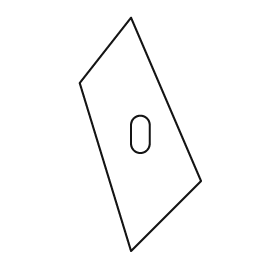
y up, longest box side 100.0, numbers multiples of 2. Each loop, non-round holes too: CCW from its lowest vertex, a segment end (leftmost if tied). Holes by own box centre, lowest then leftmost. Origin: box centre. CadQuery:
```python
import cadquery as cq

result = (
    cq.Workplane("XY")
    .moveTo(-4.0, -50.0)
    .lineTo(26.0, -20.0)
    .lineTo(-4.0, 50.0)
    .lineTo(-26.0, 22.0)
    .close()
    .moveTo(-4.0, -4.0)
    .threePointArc((0.0, -8.0), (4.0, -4.0))
    .lineTo(4.0, 4.0)
    .threePointArc((0.0, 8.0), (-4.0, 4.0))
    .close()
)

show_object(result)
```